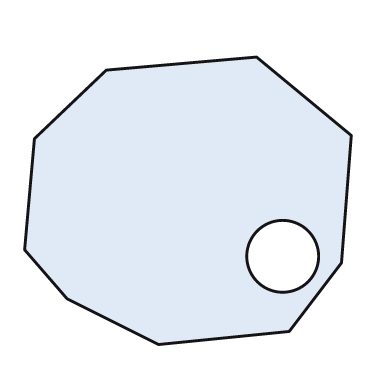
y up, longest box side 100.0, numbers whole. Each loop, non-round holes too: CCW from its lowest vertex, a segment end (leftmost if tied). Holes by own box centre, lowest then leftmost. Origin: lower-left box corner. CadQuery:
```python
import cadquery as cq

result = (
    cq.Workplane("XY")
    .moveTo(41.0, 0.0)
    .lineTo(81.0, 4.0)
    .lineTo(97.0, 25.0)
    .lineTo(100.0, 64.0)
    .lineTo(71.0, 88.0)
    .lineTo(25.0, 84.0)
    .lineTo(3.0, 63.0)
    .lineTo(0.0, 29.0)
    .lineTo(13.0, 14.0)
    .close()
    .moveTo(79.0, 27.0)
    .circle(11.0)
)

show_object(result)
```